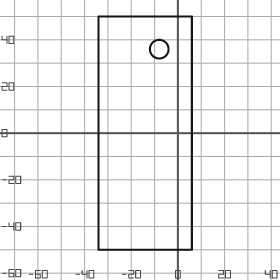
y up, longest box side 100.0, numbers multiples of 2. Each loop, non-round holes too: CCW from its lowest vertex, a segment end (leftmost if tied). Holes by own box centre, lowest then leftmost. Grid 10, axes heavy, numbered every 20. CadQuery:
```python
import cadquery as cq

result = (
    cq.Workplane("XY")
    .moveTo(-34.0, -50.0)
    .lineTo(6.0, -50.0)
    .lineTo(6.0, 50.0)
    .lineTo(-34.0, 50.0)
    .close()
    .moveTo(-8.0, 36.0)
    .circle(4.0)
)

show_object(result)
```